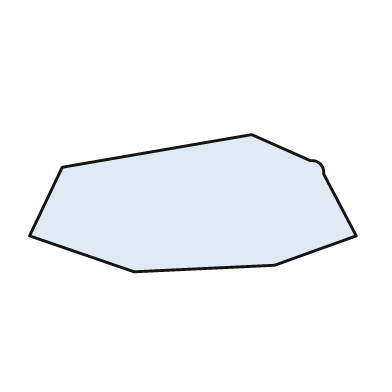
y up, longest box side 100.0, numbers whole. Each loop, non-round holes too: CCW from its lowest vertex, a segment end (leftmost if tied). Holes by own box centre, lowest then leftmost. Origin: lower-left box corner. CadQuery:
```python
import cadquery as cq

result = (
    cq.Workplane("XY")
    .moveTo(32.0, 0.0)
    .lineTo(75.0, 2.0)
    .lineTo(100.0, 11.0)
    .lineTo(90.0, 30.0)
    .threePointArc((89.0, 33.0), (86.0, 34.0))
    .lineTo(68.0, 42.0)
    .lineTo(10.0, 32.0)
    .lineTo(0.0, 11.0)
    .close()
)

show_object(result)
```